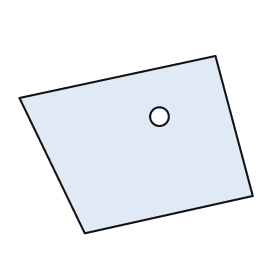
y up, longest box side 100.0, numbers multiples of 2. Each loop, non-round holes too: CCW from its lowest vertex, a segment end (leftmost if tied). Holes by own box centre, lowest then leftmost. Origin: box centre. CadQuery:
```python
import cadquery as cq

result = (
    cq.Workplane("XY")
    .moveTo(-22.0, -38.0)
    .lineTo(50.0, -22.0)
    .lineTo(34.0, 38.0)
    .lineTo(-50.0, 20.0)
    .close()
    .moveTo(10.0, 12.0)
    .circle(4.0)
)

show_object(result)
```